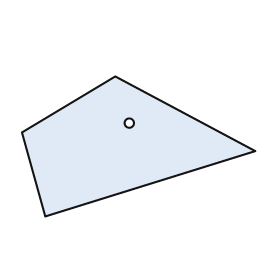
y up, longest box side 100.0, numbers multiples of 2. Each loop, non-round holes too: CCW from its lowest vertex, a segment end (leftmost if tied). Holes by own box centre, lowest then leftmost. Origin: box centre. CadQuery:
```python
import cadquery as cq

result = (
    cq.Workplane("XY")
    .moveTo(-40.0, -30.0)
    .lineTo(50.0, -2.0)
    .lineTo(-10.0, 30.0)
    .lineTo(-50.0, 6.0)
    .close()
    .moveTo(-4.0, 10.0)
    .circle(2.0)
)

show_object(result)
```